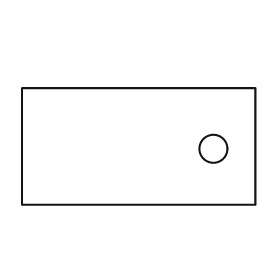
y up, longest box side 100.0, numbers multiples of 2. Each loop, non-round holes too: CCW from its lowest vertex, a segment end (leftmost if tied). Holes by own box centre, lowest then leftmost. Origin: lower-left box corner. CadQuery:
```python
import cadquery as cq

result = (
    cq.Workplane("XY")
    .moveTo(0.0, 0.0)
    .lineTo(100.0, 0.0)
    .lineTo(100.0, 50.0)
    .lineTo(0.0, 50.0)
    .close()
    .moveTo(82.0, 24.0)
    .circle(6.0)
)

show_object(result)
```